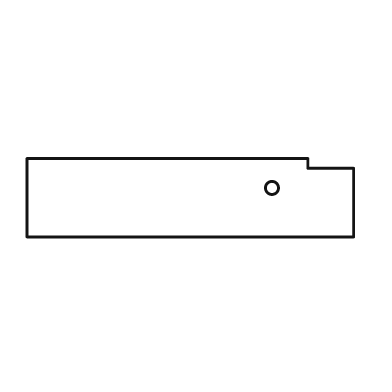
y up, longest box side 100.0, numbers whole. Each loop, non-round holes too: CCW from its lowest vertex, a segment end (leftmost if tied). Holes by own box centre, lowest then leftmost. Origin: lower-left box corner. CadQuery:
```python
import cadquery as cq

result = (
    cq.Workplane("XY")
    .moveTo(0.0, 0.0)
    .lineTo(100.0, 0.0)
    .lineTo(100.0, 21.0)
    .lineTo(86.0, 21.0)
    .lineTo(86.0, 24.0)
    .lineTo(0.0, 24.0)
    .close()
    .moveTo(75.0, 15.0)
    .circle(2.0)
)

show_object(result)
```